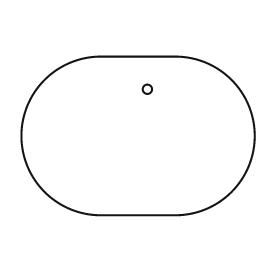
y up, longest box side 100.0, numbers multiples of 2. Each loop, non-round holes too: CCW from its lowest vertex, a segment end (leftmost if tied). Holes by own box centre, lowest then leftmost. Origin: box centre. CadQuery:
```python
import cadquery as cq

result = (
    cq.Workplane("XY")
    .moveTo(-16.0, -34.0)
    .lineTo(16.0, -34.0)
    .threePointArc((50.0, 0.0), (16.0, 34.0))
    .lineTo(-16.0, 34.0)
    .threePointArc((-50.0, 0.0), (-16.0, -34.0))
    .close()
    .moveTo(4.0, 20.0)
    .circle(2.0)
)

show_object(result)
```